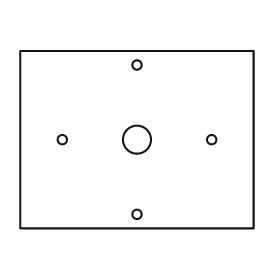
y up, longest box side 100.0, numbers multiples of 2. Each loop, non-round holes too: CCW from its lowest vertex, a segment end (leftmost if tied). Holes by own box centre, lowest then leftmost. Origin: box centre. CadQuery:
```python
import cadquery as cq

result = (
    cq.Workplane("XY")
    .moveTo(-50.0, -38.0)
    .lineTo(50.0, -38.0)
    .lineTo(50.0, 38.0)
    .lineTo(-50.0, 38.0)
    .close()
    .moveTo(0.0, -32.0)
    .circle(2.0)
    .moveTo(-32.0, 0.0)
    .circle(2.0)
    .moveTo(0.0, 0.0)
    .circle(6.0)
    .moveTo(32.0, 0.0)
    .circle(2.0)
    .moveTo(0.0, 32.0)
    .circle(2.0)
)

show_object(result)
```